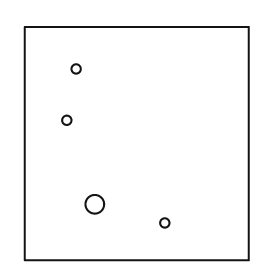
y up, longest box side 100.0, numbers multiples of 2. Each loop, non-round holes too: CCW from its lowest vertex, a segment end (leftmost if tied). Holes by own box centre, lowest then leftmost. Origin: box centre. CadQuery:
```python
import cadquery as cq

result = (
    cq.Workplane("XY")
    .moveTo(-48.0, -50.0)
    .lineTo(48.0, -50.0)
    .lineTo(48.0, 50.0)
    .lineTo(-48.0, 50.0)
    .close()
    .moveTo(12.0, -34.0)
    .circle(2.0)
    .moveTo(-18.0, -26.0)
    .circle(4.0)
    .moveTo(-30.0, 10.0)
    .circle(2.0)
    .moveTo(-26.0, 32.0)
    .circle(2.0)
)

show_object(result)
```